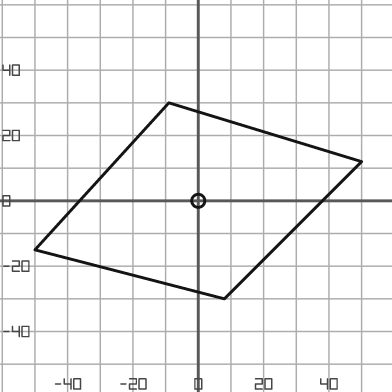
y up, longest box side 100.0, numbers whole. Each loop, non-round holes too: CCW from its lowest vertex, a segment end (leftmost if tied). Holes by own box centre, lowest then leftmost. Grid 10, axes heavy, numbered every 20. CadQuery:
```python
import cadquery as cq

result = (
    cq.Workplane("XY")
    .moveTo(8.0, -30.0)
    .lineTo(50.0, 12.0)
    .lineTo(-9.0, 30.0)
    .lineTo(-50.0, -15.0)
    .close()
    .moveTo(0.0, 0.0)
    .circle(2.0)
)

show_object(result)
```